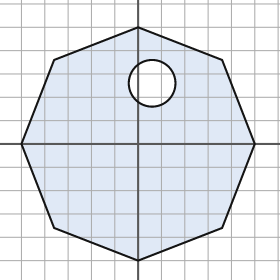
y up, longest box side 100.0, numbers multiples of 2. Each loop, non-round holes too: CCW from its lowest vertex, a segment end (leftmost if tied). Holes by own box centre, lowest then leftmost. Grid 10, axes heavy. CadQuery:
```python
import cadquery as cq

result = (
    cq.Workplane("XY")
    .moveTo(0.0, -50.0)
    .lineTo(36.0, -36.0)
    .lineTo(50.0, 0.0)
    .lineTo(36.0, 36.0)
    .lineTo(0.0, 50.0)
    .lineTo(-36.0, 36.0)
    .lineTo(-50.0, 0.0)
    .lineTo(-36.0, -36.0)
    .close()
    .moveTo(6.0, 26.0)
    .circle(10.0)
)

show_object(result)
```